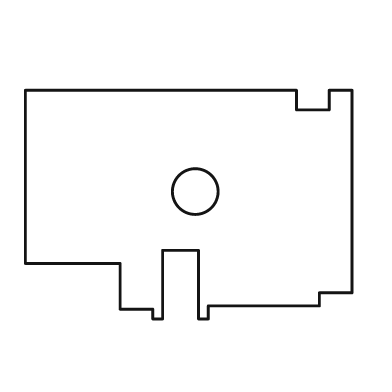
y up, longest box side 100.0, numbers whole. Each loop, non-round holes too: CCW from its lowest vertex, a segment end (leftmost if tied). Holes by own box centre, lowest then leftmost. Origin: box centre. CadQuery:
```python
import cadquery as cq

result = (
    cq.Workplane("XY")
    .moveTo(-11.0, -35.0)
    .lineTo(-8.0, -35.0)
    .lineTo(-8.0, -14.0)
    .lineTo(3.0, -14.0)
    .lineTo(3.0, -35.0)
    .lineTo(6.0, -35.0)
    .lineTo(6.0, -31.0)
    .lineTo(40.0, -31.0)
    .lineTo(40.0, -27.0)
    .lineTo(50.0, -27.0)
    .lineTo(50.0, 35.0)
    .lineTo(43.0, 35.0)
    .lineTo(43.0, 29.0)
    .lineTo(33.0, 29.0)
    .lineTo(33.0, 35.0)
    .lineTo(-50.0, 35.0)
    .lineTo(-50.0, -18.0)
    .lineTo(-21.0, -18.0)
    .lineTo(-21.0, -32.0)
    .lineTo(-11.0, -32.0)
    .close()
    .moveTo(2.0, 4.0)
    .circle(7.0)
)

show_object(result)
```